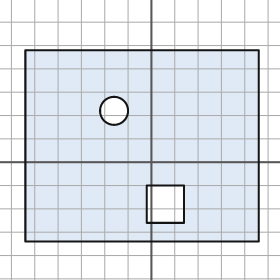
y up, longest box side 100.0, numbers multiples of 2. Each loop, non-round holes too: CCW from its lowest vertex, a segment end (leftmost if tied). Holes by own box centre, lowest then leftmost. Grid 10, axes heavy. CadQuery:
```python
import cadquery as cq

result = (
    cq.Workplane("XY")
    .moveTo(-54.0, -34.0)
    .lineTo(46.0, -34.0)
    .lineTo(46.0, 48.0)
    .lineTo(-54.0, 48.0)
    .close()
    .moveTo(-2.0, -26.0)
    .lineTo(14.0, -26.0)
    .lineTo(14.0, -10.0)
    .lineTo(-2.0, -10.0)
    .close()
    .moveTo(-16.0, 22.0)
    .circle(6.0)
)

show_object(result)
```